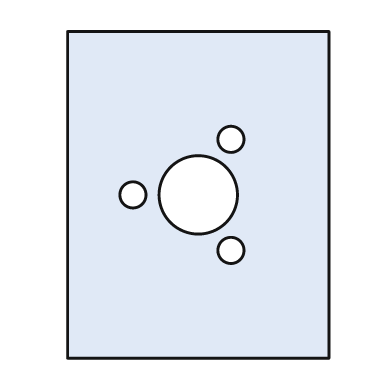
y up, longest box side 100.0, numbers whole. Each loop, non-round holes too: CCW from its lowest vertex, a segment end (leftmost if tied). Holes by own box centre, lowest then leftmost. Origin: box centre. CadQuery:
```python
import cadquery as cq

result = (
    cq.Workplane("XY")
    .moveTo(-40.0, -50.0)
    .lineTo(40.0, -50.0)
    .lineTo(40.0, 50.0)
    .lineTo(-40.0, 50.0)
    .close()
    .moveTo(10.0, -17.0)
    .circle(4.0)
    .moveTo(-20.0, 0.0)
    .circle(4.0)
    .moveTo(0.0, 0.0)
    .circle(12.0)
    .moveTo(10.0, 17.0)
    .circle(4.0)
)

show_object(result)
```